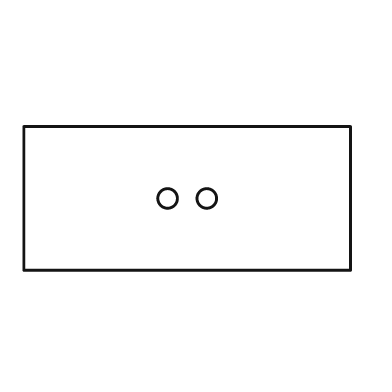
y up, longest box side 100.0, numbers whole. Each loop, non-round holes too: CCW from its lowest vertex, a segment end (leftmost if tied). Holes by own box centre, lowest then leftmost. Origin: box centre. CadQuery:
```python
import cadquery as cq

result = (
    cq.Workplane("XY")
    .moveTo(-50.0, -22.0)
    .lineTo(50.0, -22.0)
    .lineTo(50.0, 22.0)
    .lineTo(-50.0, 22.0)
    .close()
    .moveTo(-6.0, 0.0)
    .circle(3.0)
    .moveTo(6.0, 0.0)
    .circle(3.0)
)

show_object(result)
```